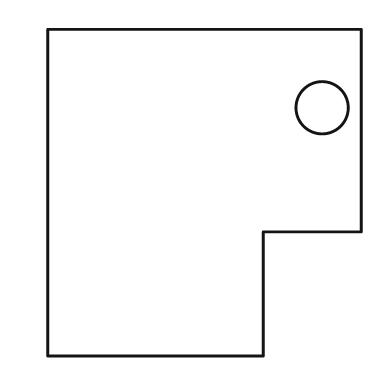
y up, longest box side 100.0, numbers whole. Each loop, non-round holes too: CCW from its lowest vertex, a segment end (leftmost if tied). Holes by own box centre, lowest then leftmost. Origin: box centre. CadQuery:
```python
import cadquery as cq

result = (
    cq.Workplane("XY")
    .moveTo(-48.0, -50.0)
    .lineTo(18.0, -50.0)
    .lineTo(18.0, -12.0)
    .lineTo(48.0, -12.0)
    .lineTo(48.0, 50.0)
    .lineTo(-48.0, 50.0)
    .close()
    .moveTo(36.0, 26.0)
    .circle(8.0)
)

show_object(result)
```